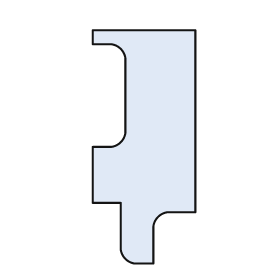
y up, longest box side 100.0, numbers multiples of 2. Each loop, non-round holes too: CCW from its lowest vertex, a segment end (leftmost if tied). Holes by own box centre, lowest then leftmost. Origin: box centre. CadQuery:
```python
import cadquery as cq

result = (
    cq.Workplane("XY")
    .moveTo(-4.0, -50.0)
    .lineTo(4.0, -50.0)
    .lineTo(4.0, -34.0)
    .threePointArc((6.0, -30.0), (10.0, -28.0))
    .lineTo(22.0, -28.0)
    .lineTo(22.0, 50.0)
    .lineTo(-22.0, 50.0)
    .lineTo(-22.0, 44.0)
    .lineTo(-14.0, 44.0)
    .threePointArc((-10.0, 42.0), (-8.0, 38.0))
    .lineTo(-8.0, 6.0)
    .threePointArc((-10.0, 2.0), (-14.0, 0.0))
    .lineTo(-22.0, 0.0)
    .lineTo(-22.0, -24.0)
    .lineTo(-10.0, -24.0)
    .lineTo(-10.0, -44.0)
    .threePointArc((-8.0, -48.0), (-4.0, -50.0))
    .close()
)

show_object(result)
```